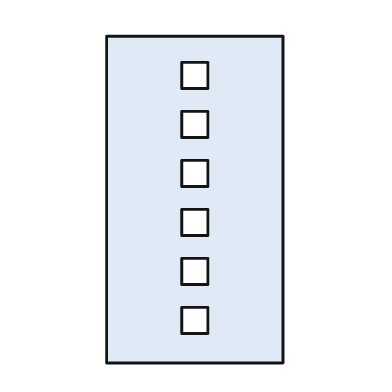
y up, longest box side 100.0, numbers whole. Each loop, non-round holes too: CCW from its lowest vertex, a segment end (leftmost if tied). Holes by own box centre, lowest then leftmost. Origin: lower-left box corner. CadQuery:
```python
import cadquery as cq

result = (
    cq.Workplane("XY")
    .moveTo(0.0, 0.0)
    .lineTo(54.0, 0.0)
    .lineTo(54.0, 100.0)
    .lineTo(0.0, 100.0)
    .close()
    .moveTo(23.0, 9.0)
    .lineTo(31.0, 9.0)
    .lineTo(31.0, 17.0)
    .lineTo(23.0, 17.0)
    .close()
    .moveTo(23.0, 24.0)
    .lineTo(31.0, 24.0)
    .lineTo(31.0, 32.0)
    .lineTo(23.0, 32.0)
    .close()
    .moveTo(23.0, 39.0)
    .lineTo(31.0, 39.0)
    .lineTo(31.0, 47.0)
    .lineTo(23.0, 47.0)
    .close()
    .moveTo(23.0, 54.0)
    .lineTo(31.0, 54.0)
    .lineTo(31.0, 62.0)
    .lineTo(23.0, 62.0)
    .close()
    .moveTo(23.0, 69.0)
    .lineTo(31.0, 69.0)
    .lineTo(31.0, 77.0)
    .lineTo(23.0, 77.0)
    .close()
    .moveTo(23.0, 84.0)
    .lineTo(31.0, 84.0)
    .lineTo(31.0, 92.0)
    .lineTo(23.0, 92.0)
    .close()
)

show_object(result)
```